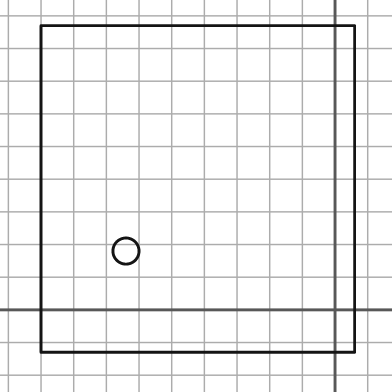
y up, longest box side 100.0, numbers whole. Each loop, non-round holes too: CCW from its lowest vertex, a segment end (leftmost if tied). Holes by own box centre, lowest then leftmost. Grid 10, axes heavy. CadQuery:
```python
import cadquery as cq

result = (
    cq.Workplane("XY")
    .moveTo(-90.0, -13.0)
    .lineTo(6.0, -13.0)
    .lineTo(6.0, 87.0)
    .lineTo(-90.0, 87.0)
    .close()
    .moveTo(-64.0, 18.0)
    .circle(4.0)
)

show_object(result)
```